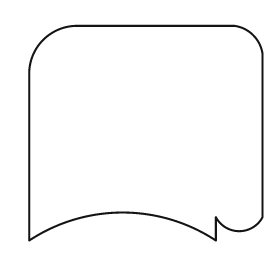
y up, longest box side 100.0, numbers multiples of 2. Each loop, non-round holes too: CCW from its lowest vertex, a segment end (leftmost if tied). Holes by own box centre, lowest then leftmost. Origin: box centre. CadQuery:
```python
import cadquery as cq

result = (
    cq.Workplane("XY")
    .moveTo(-50.0, -46.0)
    .threePointArc((-10.0, -34.0), (30.0, -46.0))
    .lineTo(30.0, -36.0)
    .threePointArc((40.0, -42.0), (50.0, -36.0))
    .lineTo(50.0, 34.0)
    .threePointArc((46.0, 42.0), (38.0, 46.0))
    .lineTo(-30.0, 46.0)
    .threePointArc((-44.0, 40.0), (-50.0, 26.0))
    .close()
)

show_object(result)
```